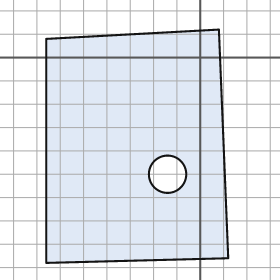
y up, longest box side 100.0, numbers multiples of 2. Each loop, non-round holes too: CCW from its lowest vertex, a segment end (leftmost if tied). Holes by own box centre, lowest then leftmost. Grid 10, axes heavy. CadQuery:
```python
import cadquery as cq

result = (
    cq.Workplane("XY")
    .moveTo(-66.0, -88.0)
    .lineTo(12.0, -86.0)
    .lineTo(8.0, 12.0)
    .lineTo(-66.0, 8.0)
    .close()
    .moveTo(-14.0, -50.0)
    .circle(8.0)
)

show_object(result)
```